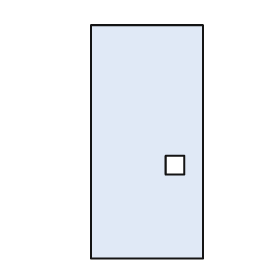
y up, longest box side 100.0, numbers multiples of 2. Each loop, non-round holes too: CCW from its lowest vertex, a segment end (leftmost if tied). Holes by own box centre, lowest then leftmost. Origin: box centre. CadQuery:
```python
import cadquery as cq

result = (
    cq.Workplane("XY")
    .moveTo(-24.0, -50.0)
    .lineTo(24.0, -50.0)
    .lineTo(24.0, 50.0)
    .lineTo(-24.0, 50.0)
    .close()
    .moveTo(8.0, -14.0)
    .lineTo(16.0, -14.0)
    .lineTo(16.0, -6.0)
    .lineTo(8.0, -6.0)
    .close()
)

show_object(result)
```